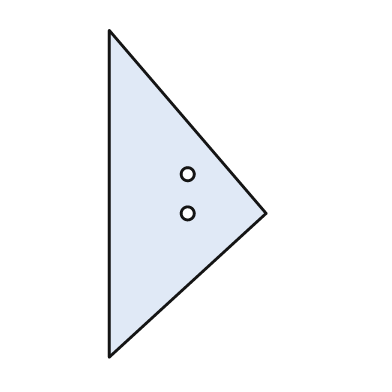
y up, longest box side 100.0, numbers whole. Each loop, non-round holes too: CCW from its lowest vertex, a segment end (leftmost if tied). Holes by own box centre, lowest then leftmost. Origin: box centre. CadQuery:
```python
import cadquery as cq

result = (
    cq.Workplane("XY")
    .moveTo(-24.0, -50.0)
    .lineTo(24.0, -6.0)
    .lineTo(-24.0, 50.0)
    .close()
    .moveTo(0.0, -6.0)
    .circle(2.0)
    .moveTo(0.0, 6.0)
    .circle(2.0)
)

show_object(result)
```